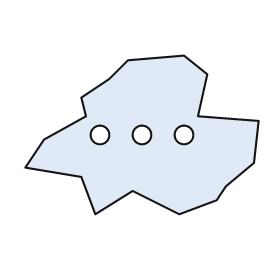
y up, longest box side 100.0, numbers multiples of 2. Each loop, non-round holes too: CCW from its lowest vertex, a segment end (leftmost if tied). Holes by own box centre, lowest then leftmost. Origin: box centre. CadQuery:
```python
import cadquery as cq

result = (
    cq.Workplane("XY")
    .moveTo(-20.0, -34.0)
    .lineTo(-4.0, -24.0)
    .lineTo(16.0, -34.0)
    .lineTo(32.0, -28.0)
    .lineTo(36.0, -22.0)
    .lineTo(48.0, -12.0)
    .lineTo(50.0, 6.0)
    .lineTo(24.0, 8.0)
    .lineTo(28.0, 26.0)
    .lineTo(18.0, 34.0)
    .lineTo(-6.0, 32.0)
    .lineTo(-14.0, 24.0)
    .lineTo(-26.0, 16.0)
    .lineTo(-24.0, 8.0)
    .lineTo(-42.0, -2.0)
    .lineTo(-50.0, -14.0)
    .lineTo(-26.0, -18.0)
    .close()
    .moveTo(-18.0, 0.0)
    .circle(4.0)
    .moveTo(0.0, 0.0)
    .circle(4.0)
    .moveTo(18.0, 0.0)
    .circle(4.0)
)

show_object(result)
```